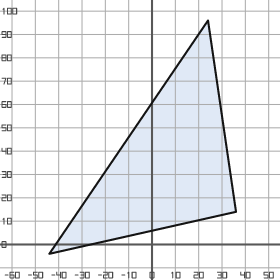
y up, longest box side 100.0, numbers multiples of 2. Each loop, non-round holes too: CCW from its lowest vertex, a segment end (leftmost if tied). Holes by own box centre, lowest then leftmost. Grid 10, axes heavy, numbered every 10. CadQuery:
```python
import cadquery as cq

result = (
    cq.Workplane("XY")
    .moveTo(-44.0, -4.0)
    .lineTo(36.0, 14.0)
    .lineTo(24.0, 96.0)
    .close()
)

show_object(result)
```